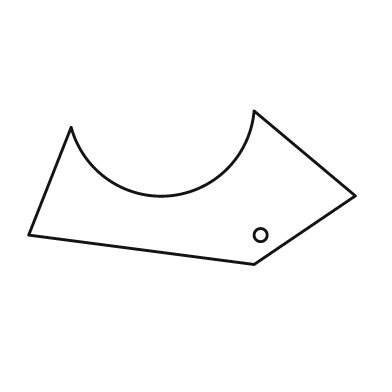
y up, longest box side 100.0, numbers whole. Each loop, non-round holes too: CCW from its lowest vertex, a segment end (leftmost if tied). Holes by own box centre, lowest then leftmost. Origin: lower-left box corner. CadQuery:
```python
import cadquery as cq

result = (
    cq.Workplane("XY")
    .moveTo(69.0, 0.0)
    .lineTo(100.0, 21.0)
    .lineTo(69.0, 47.0)
    .threePointArc((43.0, 21.0), (13.0, 42.0))
    .lineTo(0.0, 9.0)
    .close()
    .moveTo(71.0, 9.0)
    .circle(2.0)
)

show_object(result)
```